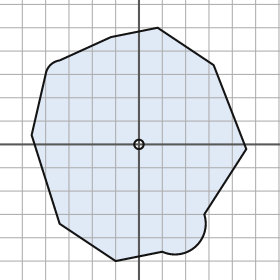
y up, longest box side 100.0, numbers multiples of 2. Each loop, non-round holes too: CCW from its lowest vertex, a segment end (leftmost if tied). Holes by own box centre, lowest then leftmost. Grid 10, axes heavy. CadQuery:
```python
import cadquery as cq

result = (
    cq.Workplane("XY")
    .moveTo(-10.0, -50.0)
    .lineTo(10.0, -46.0)
    .threePointArc((24.0, -44.0), (28.0, -30.0))
    .lineTo(46.0, -2.0)
    .lineTo(32.0, 34.0)
    .lineTo(8.0, 50.0)
    .lineTo(-12.0, 46.0)
    .lineTo(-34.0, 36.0)
    .threePointArc((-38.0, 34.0), (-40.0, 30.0))
    .lineTo(-46.0, 4.0)
    .lineTo(-34.0, -34.0)
    .close()
    .moveTo(0.0, 0.0)
    .circle(2.0)
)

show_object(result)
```